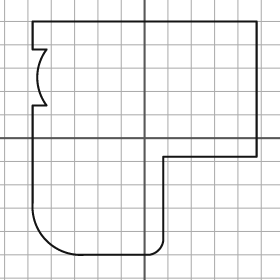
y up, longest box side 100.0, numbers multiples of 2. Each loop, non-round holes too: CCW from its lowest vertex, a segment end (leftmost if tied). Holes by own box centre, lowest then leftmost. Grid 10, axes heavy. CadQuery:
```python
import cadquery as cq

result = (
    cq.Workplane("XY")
    .moveTo(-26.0, -50.0)
    .lineTo(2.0, -50.0)
    .threePointArc((6.0, -48.0), (8.0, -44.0))
    .lineTo(8.0, -8.0)
    .lineTo(48.0, -8.0)
    .lineTo(48.0, 50.0)
    .lineTo(-48.0, 50.0)
    .lineTo(-48.0, 38.0)
    .lineTo(-42.0, 38.0)
    .threePointArc((-46.0, 26.0), (-42.0, 14.0))
    .lineTo(-48.0, 14.0)
    .lineTo(-48.0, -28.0)
    .threePointArc((-42.0, -44.0), (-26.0, -50.0))
    .close()
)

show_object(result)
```